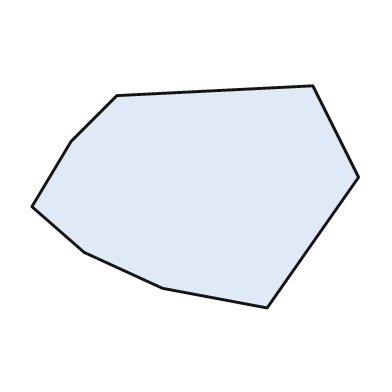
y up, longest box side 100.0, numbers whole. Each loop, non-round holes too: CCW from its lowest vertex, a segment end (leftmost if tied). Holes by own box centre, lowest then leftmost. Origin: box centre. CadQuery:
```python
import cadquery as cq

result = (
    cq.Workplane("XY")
    .moveTo(22.0, -34.0)
    .lineTo(50.0, 6.0)
    .lineTo(36.0, 34.0)
    .lineTo(-24.0, 31.0)
    .lineTo(-38.0, 17.0)
    .lineTo(-50.0, -3.0)
    .lineTo(-34.0, -17.0)
    .lineTo(-10.0, -28.0)
    .close()
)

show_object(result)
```